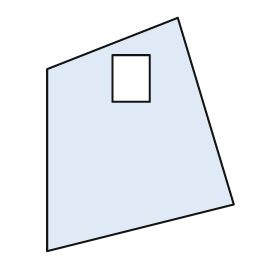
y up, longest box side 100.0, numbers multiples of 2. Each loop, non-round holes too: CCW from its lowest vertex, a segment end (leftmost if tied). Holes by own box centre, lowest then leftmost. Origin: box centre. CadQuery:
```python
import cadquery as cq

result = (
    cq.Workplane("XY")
    .moveTo(-40.0, -50.0)
    .lineTo(40.0, -30.0)
    .lineTo(16.0, 50.0)
    .lineTo(-40.0, 28.0)
    .close()
    .moveTo(-12.0, 14.0)
    .lineTo(4.0, 14.0)
    .lineTo(4.0, 34.0)
    .lineTo(-12.0, 34.0)
    .close()
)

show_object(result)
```